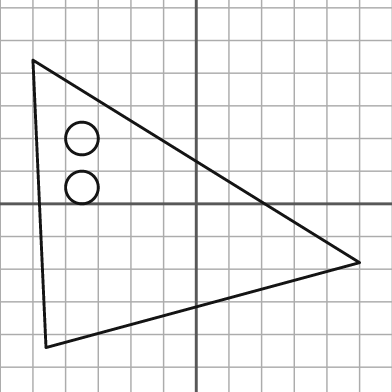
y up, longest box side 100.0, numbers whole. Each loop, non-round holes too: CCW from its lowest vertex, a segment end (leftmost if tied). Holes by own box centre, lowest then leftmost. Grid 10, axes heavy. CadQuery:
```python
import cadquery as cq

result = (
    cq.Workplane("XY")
    .moveTo(-46.0, -44.0)
    .lineTo(50.0, -18.0)
    .lineTo(-50.0, 44.0)
    .close()
    .moveTo(-35.0, 5.0)
    .circle(5.0)
    .moveTo(-35.0, 20.0)
    .circle(5.0)
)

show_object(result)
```